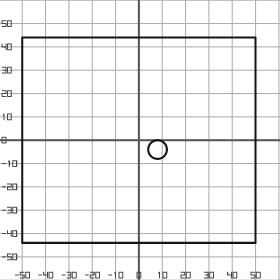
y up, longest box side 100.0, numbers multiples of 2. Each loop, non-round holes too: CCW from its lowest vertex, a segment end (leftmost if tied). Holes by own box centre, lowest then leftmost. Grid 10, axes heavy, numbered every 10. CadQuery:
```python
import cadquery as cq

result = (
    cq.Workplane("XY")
    .moveTo(-50.0, -44.0)
    .lineTo(50.0, -44.0)
    .lineTo(50.0, 44.0)
    .lineTo(-50.0, 44.0)
    .close()
    .moveTo(8.0, -4.0)
    .circle(4.0)
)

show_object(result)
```